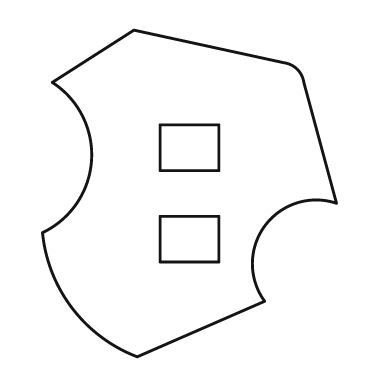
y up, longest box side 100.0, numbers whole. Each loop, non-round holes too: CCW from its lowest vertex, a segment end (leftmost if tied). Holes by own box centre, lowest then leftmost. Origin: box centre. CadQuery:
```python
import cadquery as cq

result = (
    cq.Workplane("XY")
    .moveTo(-16.0, -50.0)
    .lineTo(23.0, -33.0)
    .threePointArc((23.0, -10.0), (45.0, -3.0))
    .lineTo(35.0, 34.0)
    .threePointArc((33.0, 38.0), (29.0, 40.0))
    .lineTo(-17.0, 50.0)
    .lineTo(-42.0, 34.0)
    .threePointArc((-30.0, 10.0), (-45.0, -12.0))
    .threePointArc((-36.0, -35.0), (-16.0, -50.0))
    .close()
    .moveTo(-9.0, -21.0)
    .lineTo(9.0, -21.0)
    .lineTo(9.0, -7.0)
    .lineTo(-9.0, -7.0)
    .close()
    .moveTo(-9.0, 7.0)
    .lineTo(9.0, 7.0)
    .lineTo(9.0, 21.0)
    .lineTo(-9.0, 21.0)
    .close()
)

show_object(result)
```